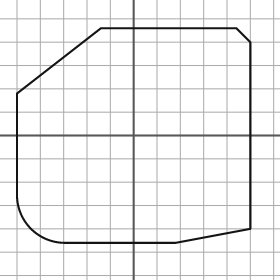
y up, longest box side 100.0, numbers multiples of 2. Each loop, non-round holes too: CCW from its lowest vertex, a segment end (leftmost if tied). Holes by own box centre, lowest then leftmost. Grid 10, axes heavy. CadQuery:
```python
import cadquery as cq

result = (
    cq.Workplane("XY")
    .moveTo(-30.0, -46.0)
    .lineTo(18.0, -46.0)
    .lineTo(50.0, -40.0)
    .lineTo(50.0, 40.0)
    .lineTo(44.0, 46.0)
    .lineTo(-14.0, 46.0)
    .lineTo(-50.0, 18.0)
    .lineTo(-50.0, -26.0)
    .threePointArc((-44.0, -40.0), (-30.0, -46.0))
    .close()
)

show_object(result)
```